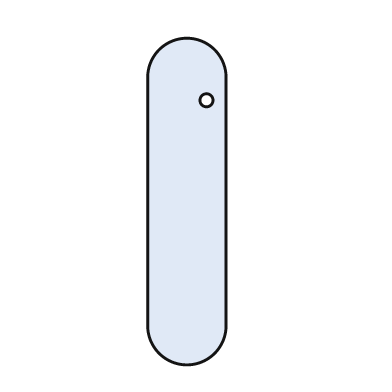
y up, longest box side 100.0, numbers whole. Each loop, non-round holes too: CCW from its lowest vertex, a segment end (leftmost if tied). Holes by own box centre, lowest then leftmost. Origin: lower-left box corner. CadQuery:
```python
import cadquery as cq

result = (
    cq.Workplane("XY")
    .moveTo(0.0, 12.0)
    .threePointArc((12.0, 0.0), (24.0, 12.0))
    .lineTo(24.0, 88.0)
    .threePointArc((12.0, 100.0), (0.0, 88.0))
    .close()
    .moveTo(18.0, 81.0)
    .circle(2.0)
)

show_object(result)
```